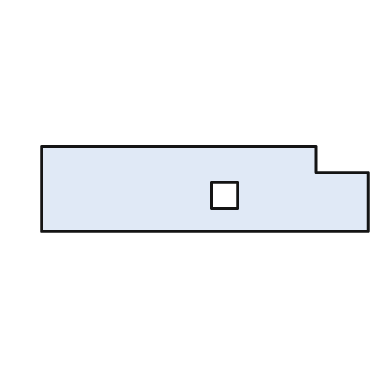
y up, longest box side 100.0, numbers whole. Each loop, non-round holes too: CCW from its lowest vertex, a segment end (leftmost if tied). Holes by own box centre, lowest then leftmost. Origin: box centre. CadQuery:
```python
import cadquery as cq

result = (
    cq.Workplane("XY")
    .moveTo(-50.0, -13.0)
    .lineTo(50.0, -13.0)
    .lineTo(50.0, 5.0)
    .lineTo(34.0, 5.0)
    .lineTo(34.0, 13.0)
    .lineTo(-50.0, 13.0)
    .close()
    .moveTo(2.0, -6.0)
    .lineTo(10.0, -6.0)
    .lineTo(10.0, 2.0)
    .lineTo(2.0, 2.0)
    .close()
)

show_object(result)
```